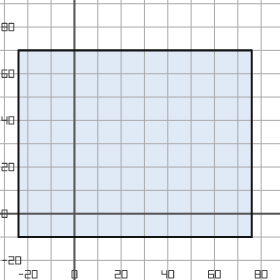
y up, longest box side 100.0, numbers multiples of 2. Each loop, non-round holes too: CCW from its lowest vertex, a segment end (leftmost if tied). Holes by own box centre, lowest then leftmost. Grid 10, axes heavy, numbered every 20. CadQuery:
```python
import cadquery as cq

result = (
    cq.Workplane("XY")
    .moveTo(-24.0, -10.0)
    .lineTo(76.0, -10.0)
    .lineTo(76.0, 70.0)
    .lineTo(-24.0, 70.0)
    .close()
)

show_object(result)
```